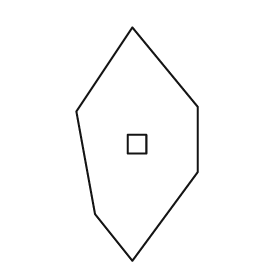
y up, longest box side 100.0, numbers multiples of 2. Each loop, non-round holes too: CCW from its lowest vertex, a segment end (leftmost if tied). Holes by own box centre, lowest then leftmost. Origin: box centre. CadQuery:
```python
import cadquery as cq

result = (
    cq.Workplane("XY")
    .moveTo(-2.0, -50.0)
    .lineTo(26.0, -12.0)
    .lineTo(26.0, 16.0)
    .lineTo(-2.0, 50.0)
    .lineTo(-26.0, 14.0)
    .lineTo(-18.0, -30.0)
    .close()
    .moveTo(-4.0, -4.0)
    .lineTo(4.0, -4.0)
    .lineTo(4.0, 4.0)
    .lineTo(-4.0, 4.0)
    .close()
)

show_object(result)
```